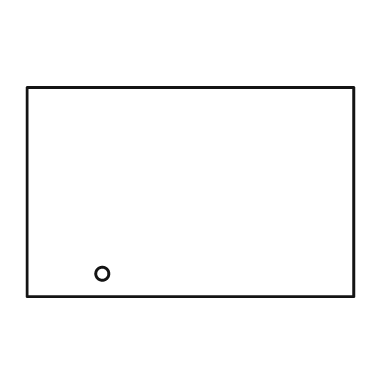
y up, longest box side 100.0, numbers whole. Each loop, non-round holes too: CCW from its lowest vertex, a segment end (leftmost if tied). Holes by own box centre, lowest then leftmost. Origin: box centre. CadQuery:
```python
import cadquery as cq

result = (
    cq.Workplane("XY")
    .moveTo(-50.0, -32.0)
    .lineTo(50.0, -32.0)
    .lineTo(50.0, 32.0)
    .lineTo(-50.0, 32.0)
    .close()
    .moveTo(-27.0, -25.0)
    .circle(2.0)
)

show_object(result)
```